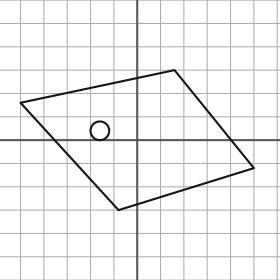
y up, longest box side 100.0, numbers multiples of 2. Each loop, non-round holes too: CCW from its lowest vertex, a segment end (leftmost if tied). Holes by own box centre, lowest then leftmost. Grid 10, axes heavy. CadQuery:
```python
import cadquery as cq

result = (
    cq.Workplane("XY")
    .moveTo(-8.0, -30.0)
    .lineTo(50.0, -12.0)
    .lineTo(16.0, 30.0)
    .lineTo(-50.0, 16.0)
    .close()
    .moveTo(-16.0, 4.0)
    .circle(4.0)
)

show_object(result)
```